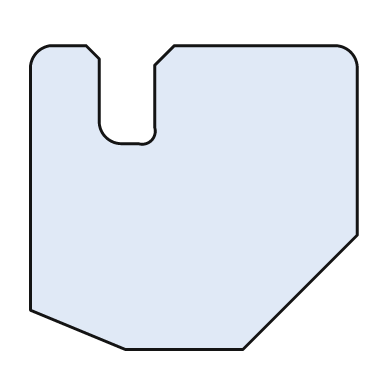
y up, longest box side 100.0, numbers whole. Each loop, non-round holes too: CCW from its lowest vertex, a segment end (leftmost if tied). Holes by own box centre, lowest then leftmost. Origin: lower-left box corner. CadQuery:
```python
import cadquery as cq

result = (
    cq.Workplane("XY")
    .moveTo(29.0, 0.0)
    .lineTo(65.0, 0.0)
    .lineTo(100.0, 35.0)
    .lineTo(100.0, 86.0)
    .threePointArc((98.0, 91.0), (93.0, 93.0))
    .lineTo(44.0, 93.0)
    .lineTo(38.0, 87.0)
    .lineTo(38.0, 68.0)
    .threePointArc((37.0, 64.0), (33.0, 63.0))
    .lineTo(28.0, 63.0)
    .threePointArc((23.0, 65.0), (21.0, 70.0))
    .lineTo(21.0, 89.0)
    .lineTo(17.0, 93.0)
    .lineTo(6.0, 93.0)
    .threePointArc((2.0, 91.0), (0.0, 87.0))
    .lineTo(0.0, 12.0)
    .close()
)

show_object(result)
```